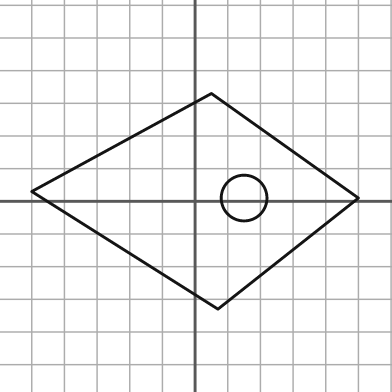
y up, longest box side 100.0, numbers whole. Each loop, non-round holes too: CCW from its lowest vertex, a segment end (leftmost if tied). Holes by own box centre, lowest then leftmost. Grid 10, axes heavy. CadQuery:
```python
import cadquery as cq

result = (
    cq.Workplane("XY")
    .moveTo(7.0, -33.0)
    .lineTo(50.0, 1.0)
    .lineTo(5.0, 33.0)
    .lineTo(-50.0, 3.0)
    .close()
    .moveTo(15.0, 1.0)
    .circle(7.0)
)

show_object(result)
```